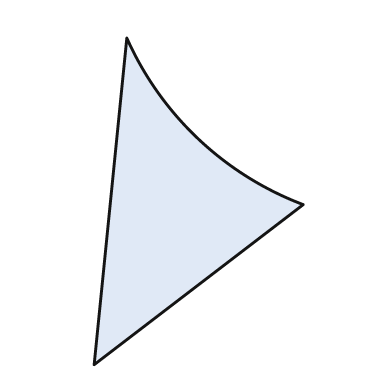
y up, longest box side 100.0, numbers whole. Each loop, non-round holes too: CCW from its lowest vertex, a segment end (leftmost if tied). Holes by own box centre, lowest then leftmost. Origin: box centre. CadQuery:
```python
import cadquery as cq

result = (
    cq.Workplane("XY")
    .moveTo(-32.0, -50.0)
    .lineTo(32.0, -1.0)
    .threePointArc((0.0, 19.0), (-22.0, 50.0))
    .close()
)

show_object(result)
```